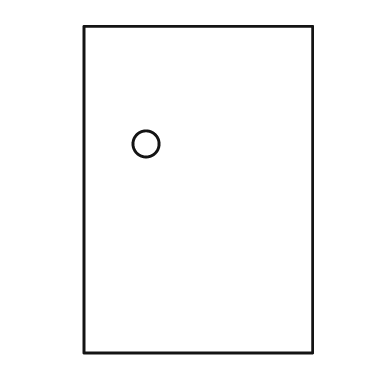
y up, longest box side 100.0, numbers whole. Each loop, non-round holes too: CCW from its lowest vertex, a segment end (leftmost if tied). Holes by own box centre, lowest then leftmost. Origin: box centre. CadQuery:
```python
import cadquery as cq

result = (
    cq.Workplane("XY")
    .moveTo(-35.0, -50.0)
    .lineTo(35.0, -50.0)
    .lineTo(35.0, 50.0)
    .lineTo(-35.0, 50.0)
    .close()
    .moveTo(-16.0, 14.0)
    .circle(4.0)
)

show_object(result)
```